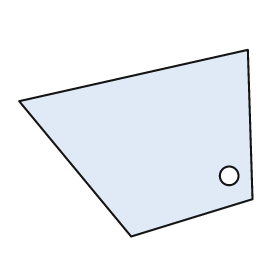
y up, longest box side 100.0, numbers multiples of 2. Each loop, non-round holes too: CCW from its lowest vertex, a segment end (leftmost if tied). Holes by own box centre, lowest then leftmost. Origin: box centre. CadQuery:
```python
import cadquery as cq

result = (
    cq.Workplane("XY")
    .moveTo(-2.0, -40.0)
    .lineTo(50.0, -24.0)
    .lineTo(48.0, 40.0)
    .lineTo(-50.0, 18.0)
    .close()
    .moveTo(40.0, -14.0)
    .circle(4.0)
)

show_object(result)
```